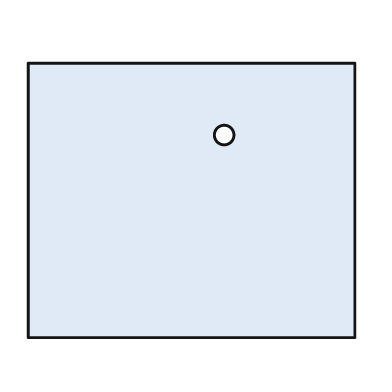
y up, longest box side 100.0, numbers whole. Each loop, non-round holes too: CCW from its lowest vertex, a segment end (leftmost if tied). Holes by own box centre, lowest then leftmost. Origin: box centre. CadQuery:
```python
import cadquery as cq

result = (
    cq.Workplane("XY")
    .moveTo(-50.0, -42.0)
    .lineTo(50.0, -42.0)
    .lineTo(50.0, 42.0)
    .lineTo(-50.0, 42.0)
    .close()
    .moveTo(10.0, 20.0)
    .circle(3.0)
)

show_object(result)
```